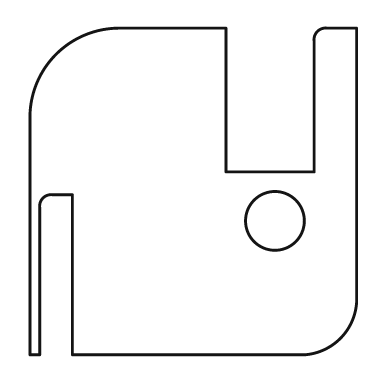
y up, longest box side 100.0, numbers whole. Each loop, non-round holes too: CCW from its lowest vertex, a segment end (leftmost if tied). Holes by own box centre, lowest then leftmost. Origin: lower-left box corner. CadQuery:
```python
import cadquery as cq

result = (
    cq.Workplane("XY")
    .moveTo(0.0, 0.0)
    .lineTo(3.0, 0.0)
    .lineTo(3.0, 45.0)
    .threePointArc((4.0, 48.0), (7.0, 49.0))
    .lineTo(13.0, 49.0)
    .lineTo(13.0, 0.0)
    .lineTo(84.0, 0.0)
    .threePointArc((95.0, 5.0), (100.0, 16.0))
    .lineTo(100.0, 100.0)
    .lineTo(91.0, 100.0)
    .threePointArc((88.0, 99.0), (87.0, 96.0))
    .lineTo(87.0, 56.0)
    .lineTo(60.0, 56.0)
    .lineTo(60.0, 100.0)
    .lineTo(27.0, 100.0)
    .threePointArc((8.0, 92.0), (0.0, 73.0))
    .close()
    .moveTo(75.0, 41.0)
    .circle(9.0)
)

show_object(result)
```